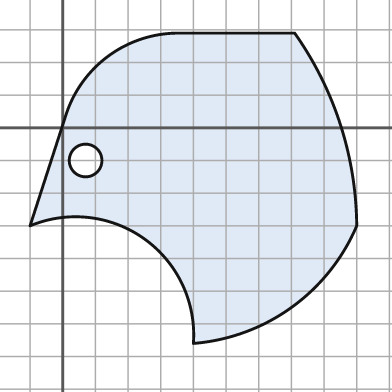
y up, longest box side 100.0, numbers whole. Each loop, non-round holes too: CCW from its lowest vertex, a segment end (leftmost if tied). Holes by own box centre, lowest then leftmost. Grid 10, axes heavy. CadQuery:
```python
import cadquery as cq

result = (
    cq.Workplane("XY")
    .moveTo(40.0, -66.0)
    .threePointArc((70.0, -55.0), (90.0, -30.0))
    .threePointArc((85.0, 1.0), (71.0, 29.0))
    .lineTo(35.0, 29.0)
    .threePointArc((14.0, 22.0), (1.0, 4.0))
    .lineTo(-10.0, -30.0)
    .threePointArc((25.0, -34.0), (40.0, -66.0))
    .close()
    .moveTo(7.0, -10.0)
    .circle(5.0)
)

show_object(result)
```